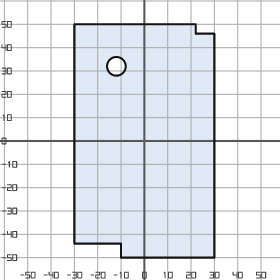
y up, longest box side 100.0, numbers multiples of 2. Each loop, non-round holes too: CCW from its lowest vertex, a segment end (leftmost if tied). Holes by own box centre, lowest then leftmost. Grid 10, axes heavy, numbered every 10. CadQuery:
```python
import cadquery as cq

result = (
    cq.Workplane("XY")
    .moveTo(-10.0, -50.0)
    .lineTo(30.0, -50.0)
    .lineTo(30.0, 46.0)
    .lineTo(22.0, 46.0)
    .lineTo(22.0, 50.0)
    .lineTo(-30.0, 50.0)
    .lineTo(-30.0, -44.0)
    .lineTo(-10.0, -44.0)
    .close()
    .moveTo(-12.0, 32.0)
    .circle(4.0)
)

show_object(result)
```